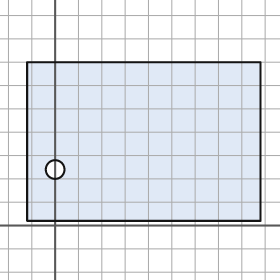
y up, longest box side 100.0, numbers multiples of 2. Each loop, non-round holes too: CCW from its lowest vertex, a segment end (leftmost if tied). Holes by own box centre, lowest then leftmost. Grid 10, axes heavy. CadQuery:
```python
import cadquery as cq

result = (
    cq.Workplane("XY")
    .moveTo(-12.0, 2.0)
    .lineTo(88.0, 2.0)
    .lineTo(88.0, 70.0)
    .lineTo(-12.0, 70.0)
    .close()
    .moveTo(0.0, 24.0)
    .circle(4.0)
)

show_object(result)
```